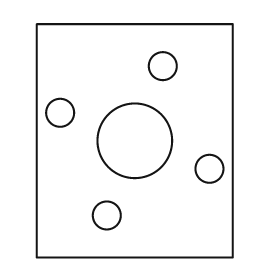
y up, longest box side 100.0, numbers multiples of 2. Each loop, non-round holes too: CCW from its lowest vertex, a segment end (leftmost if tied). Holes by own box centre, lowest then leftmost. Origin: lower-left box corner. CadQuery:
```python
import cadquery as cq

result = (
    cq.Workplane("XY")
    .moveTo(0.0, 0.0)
    .lineTo(84.0, 0.0)
    .lineTo(84.0, 100.0)
    .lineTo(0.0, 100.0)
    .close()
    .moveTo(30.0, 18.0)
    .circle(6.0)
    .moveTo(74.0, 38.0)
    .circle(6.0)
    .moveTo(42.0, 50.0)
    .circle(16.0)
    .moveTo(10.0, 62.0)
    .circle(6.0)
    .moveTo(54.0, 82.0)
    .circle(6.0)
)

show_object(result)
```